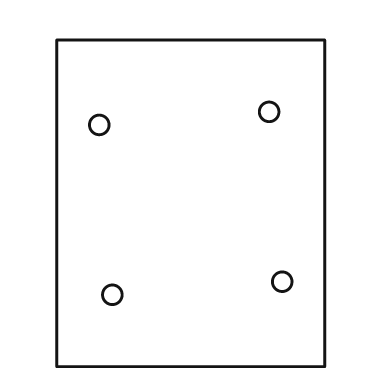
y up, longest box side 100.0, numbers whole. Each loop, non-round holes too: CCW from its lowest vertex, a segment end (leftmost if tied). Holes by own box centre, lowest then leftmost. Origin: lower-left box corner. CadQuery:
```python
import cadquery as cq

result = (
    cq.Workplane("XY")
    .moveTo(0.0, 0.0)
    .lineTo(82.0, 0.0)
    .lineTo(82.0, 100.0)
    .lineTo(0.0, 100.0)
    .close()
    .moveTo(17.0, 22.0)
    .circle(3.0)
    .moveTo(69.0, 26.0)
    .circle(3.0)
    .moveTo(13.0, 74.0)
    .circle(3.0)
    .moveTo(65.0, 78.0)
    .circle(3.0)
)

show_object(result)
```